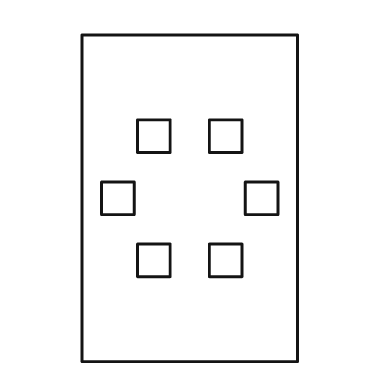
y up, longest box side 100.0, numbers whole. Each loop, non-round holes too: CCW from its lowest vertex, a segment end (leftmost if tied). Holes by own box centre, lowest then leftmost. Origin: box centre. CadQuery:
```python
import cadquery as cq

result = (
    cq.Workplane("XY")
    .moveTo(-33.0, -50.0)
    .lineTo(33.0, -50.0)
    .lineTo(33.0, 50.0)
    .lineTo(-33.0, 50.0)
    .close()
    .moveTo(-16.0, -24.0)
    .lineTo(-6.0, -24.0)
    .lineTo(-6.0, -14.0)
    .lineTo(-16.0, -14.0)
    .close()
    .moveTo(6.0, -24.0)
    .lineTo(16.0, -24.0)
    .lineTo(16.0, -14.0)
    .lineTo(6.0, -14.0)
    .close()
    .moveTo(-27.0, -5.0)
    .lineTo(-17.0, -5.0)
    .lineTo(-17.0, 5.0)
    .lineTo(-27.0, 5.0)
    .close()
    .moveTo(17.0, -5.0)
    .lineTo(27.0, -5.0)
    .lineTo(27.0, 5.0)
    .lineTo(17.0, 5.0)
    .close()
    .moveTo(-16.0, 14.0)
    .lineTo(-6.0, 14.0)
    .lineTo(-6.0, 24.0)
    .lineTo(-16.0, 24.0)
    .close()
    .moveTo(6.0, 14.0)
    .lineTo(16.0, 14.0)
    .lineTo(16.0, 24.0)
    .lineTo(6.0, 24.0)
    .close()
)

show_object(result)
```